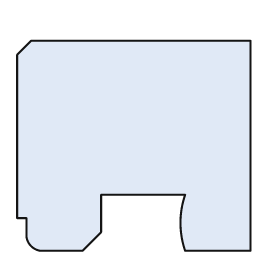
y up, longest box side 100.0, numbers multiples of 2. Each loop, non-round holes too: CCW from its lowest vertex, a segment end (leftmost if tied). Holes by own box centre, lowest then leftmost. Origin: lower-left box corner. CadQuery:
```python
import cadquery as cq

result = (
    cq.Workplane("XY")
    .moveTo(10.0, 0.0)
    .lineTo(28.0, 0.0)
    .lineTo(36.0, 8.0)
    .lineTo(36.0, 24.0)
    .lineTo(72.0, 24.0)
    .threePointArc((70.0, 12.0), (72.0, 0.0))
    .lineTo(100.0, 0.0)
    .lineTo(100.0, 90.0)
    .lineTo(6.0, 90.0)
    .lineTo(0.0, 84.0)
    .lineTo(0.0, 14.0)
    .lineTo(4.0, 14.0)
    .lineTo(4.0, 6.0)
    .threePointArc((6.0, 2.0), (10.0, 0.0))
    .close()
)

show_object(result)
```